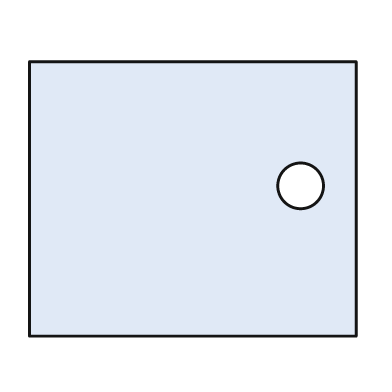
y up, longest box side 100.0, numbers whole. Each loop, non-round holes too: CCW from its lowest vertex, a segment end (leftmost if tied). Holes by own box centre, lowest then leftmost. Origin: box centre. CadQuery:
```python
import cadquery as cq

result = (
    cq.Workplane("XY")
    .moveTo(-50.0, -42.0)
    .lineTo(50.0, -42.0)
    .lineTo(50.0, 42.0)
    .lineTo(-50.0, 42.0)
    .close()
    .moveTo(33.0, 4.0)
    .circle(7.0)
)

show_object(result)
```